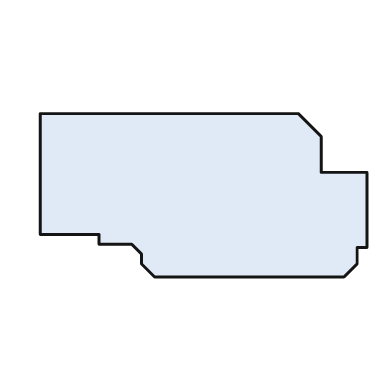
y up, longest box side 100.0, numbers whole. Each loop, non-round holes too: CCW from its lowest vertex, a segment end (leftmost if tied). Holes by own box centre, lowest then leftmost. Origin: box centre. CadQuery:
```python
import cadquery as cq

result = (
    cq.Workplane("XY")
    .moveTo(-15.0, -25.0)
    .lineTo(43.0, -25.0)
    .lineTo(47.0, -21.0)
    .lineTo(47.0, -16.0)
    .lineTo(50.0, -16.0)
    .lineTo(50.0, 7.0)
    .lineTo(36.0, 7.0)
    .lineTo(36.0, 18.0)
    .lineTo(29.0, 25.0)
    .lineTo(-50.0, 25.0)
    .lineTo(-50.0, -12.0)
    .lineTo(-32.0, -12.0)
    .lineTo(-32.0, -15.0)
    .lineTo(-22.0, -15.0)
    .lineTo(-19.0, -18.0)
    .lineTo(-19.0, -21.0)
    .close()
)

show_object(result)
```